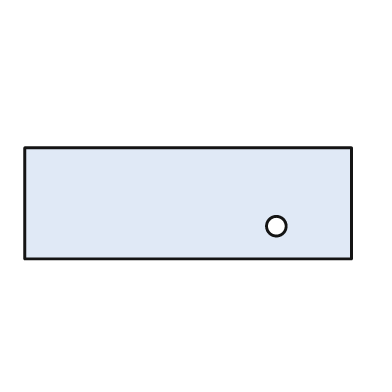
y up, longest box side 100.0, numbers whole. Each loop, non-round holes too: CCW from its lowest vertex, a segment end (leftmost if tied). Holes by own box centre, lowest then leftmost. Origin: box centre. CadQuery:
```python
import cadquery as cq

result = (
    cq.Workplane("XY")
    .moveTo(-50.0, -17.0)
    .lineTo(50.0, -17.0)
    .lineTo(50.0, 17.0)
    .lineTo(-50.0, 17.0)
    .close()
    .moveTo(27.0, -7.0)
    .circle(3.0)
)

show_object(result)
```